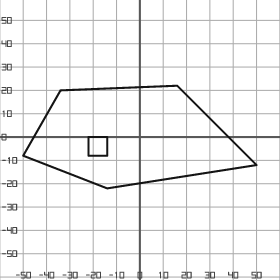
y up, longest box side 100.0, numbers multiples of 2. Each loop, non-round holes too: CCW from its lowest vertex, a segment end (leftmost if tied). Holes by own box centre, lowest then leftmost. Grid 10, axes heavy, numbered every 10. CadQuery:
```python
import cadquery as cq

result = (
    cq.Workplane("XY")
    .moveTo(-14.0, -22.0)
    .lineTo(50.0, -12.0)
    .lineTo(16.0, 22.0)
    .lineTo(-34.0, 20.0)
    .lineTo(-50.0, -8.0)
    .close()
    .moveTo(-22.0, -8.0)
    .lineTo(-14.0, -8.0)
    .lineTo(-14.0, 0.0)
    .lineTo(-22.0, 0.0)
    .close()
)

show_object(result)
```